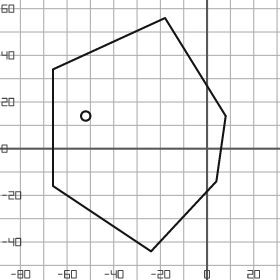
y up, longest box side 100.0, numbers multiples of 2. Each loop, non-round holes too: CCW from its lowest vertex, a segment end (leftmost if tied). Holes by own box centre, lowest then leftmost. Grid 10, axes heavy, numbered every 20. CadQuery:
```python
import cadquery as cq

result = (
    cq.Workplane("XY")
    .moveTo(-24.0, -44.0)
    .lineTo(4.0, -14.0)
    .lineTo(8.0, 14.0)
    .lineTo(-18.0, 56.0)
    .lineTo(-66.0, 34.0)
    .lineTo(-66.0, -16.0)
    .close()
    .moveTo(-52.0, 14.0)
    .circle(2.0)
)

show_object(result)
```